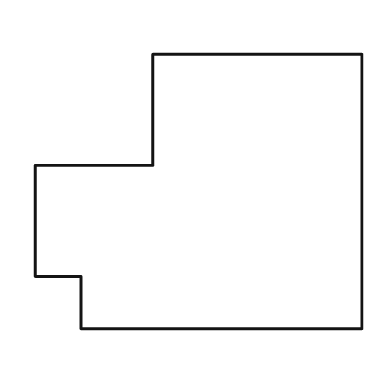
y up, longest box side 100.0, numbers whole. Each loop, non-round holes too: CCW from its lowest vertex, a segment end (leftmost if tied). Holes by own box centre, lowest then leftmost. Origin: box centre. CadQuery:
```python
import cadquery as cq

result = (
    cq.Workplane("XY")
    .moveTo(-36.0, -42.0)
    .lineTo(50.0, -42.0)
    .lineTo(50.0, 42.0)
    .lineTo(-14.0, 42.0)
    .lineTo(-14.0, 8.0)
    .lineTo(-50.0, 8.0)
    .lineTo(-50.0, -26.0)
    .lineTo(-36.0, -26.0)
    .close()
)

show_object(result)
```